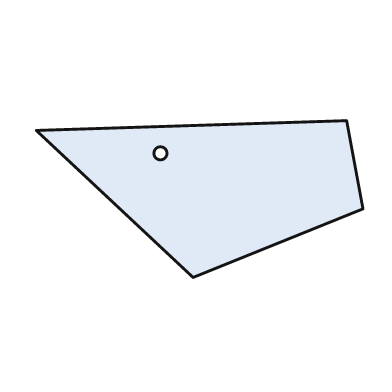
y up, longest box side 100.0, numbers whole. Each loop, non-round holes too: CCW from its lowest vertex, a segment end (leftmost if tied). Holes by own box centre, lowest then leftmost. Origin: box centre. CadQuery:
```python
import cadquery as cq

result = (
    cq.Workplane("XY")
    .moveTo(-2.0, -24.0)
    .lineTo(50.0, -3.0)
    .lineTo(45.0, 24.0)
    .lineTo(-50.0, 21.0)
    .close()
    .moveTo(-12.0, 14.0)
    .circle(2.0)
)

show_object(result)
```